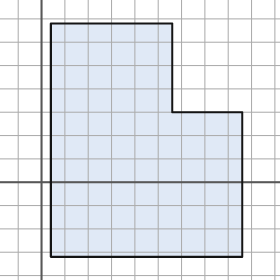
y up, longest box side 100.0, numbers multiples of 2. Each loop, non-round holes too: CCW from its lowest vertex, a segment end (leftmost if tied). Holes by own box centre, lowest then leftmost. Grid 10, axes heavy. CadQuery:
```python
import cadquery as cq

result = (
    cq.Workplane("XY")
    .moveTo(4.0, -32.0)
    .lineTo(86.0, -32.0)
    .lineTo(86.0, 30.0)
    .lineTo(56.0, 30.0)
    .lineTo(56.0, 68.0)
    .lineTo(4.0, 68.0)
    .close()
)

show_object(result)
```